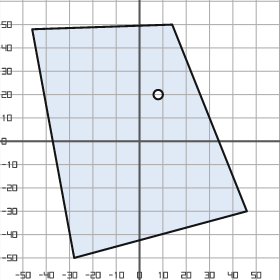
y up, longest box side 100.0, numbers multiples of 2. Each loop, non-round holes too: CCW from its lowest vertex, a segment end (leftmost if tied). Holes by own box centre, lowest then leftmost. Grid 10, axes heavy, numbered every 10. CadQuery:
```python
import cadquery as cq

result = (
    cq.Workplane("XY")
    .moveTo(-28.0, -50.0)
    .lineTo(46.0, -30.0)
    .lineTo(14.0, 50.0)
    .lineTo(-46.0, 48.0)
    .close()
    .moveTo(8.0, 20.0)
    .circle(2.0)
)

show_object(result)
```